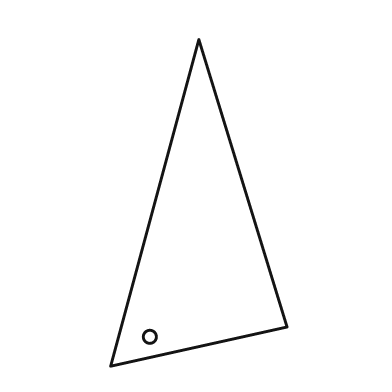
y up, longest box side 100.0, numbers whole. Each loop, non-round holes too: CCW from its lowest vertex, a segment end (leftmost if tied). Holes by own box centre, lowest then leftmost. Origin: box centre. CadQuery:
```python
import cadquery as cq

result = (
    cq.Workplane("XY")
    .moveTo(-27.0, -50.0)
    .lineTo(27.0, -38.0)
    .lineTo(0.0, 50.0)
    .close()
    .moveTo(-15.0, -41.0)
    .circle(2.0)
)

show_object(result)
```